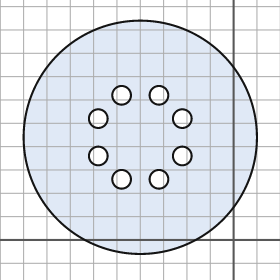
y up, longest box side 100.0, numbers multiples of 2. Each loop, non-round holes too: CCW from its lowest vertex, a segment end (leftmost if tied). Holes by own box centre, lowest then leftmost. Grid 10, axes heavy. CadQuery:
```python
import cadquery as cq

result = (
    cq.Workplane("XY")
    .moveTo(-40.0, 44.0)
    .circle(50.0)
    .moveTo(-48.0, 26.0)
    .circle(4.0)
    .moveTo(-32.0, 26.0)
    .circle(4.0)
    .moveTo(-58.0, 36.0)
    .circle(4.0)
    .moveTo(-22.0, 36.0)
    .circle(4.0)
    .moveTo(-58.0, 52.0)
    .circle(4.0)
    .moveTo(-22.0, 52.0)
    .circle(4.0)
    .moveTo(-48.0, 62.0)
    .circle(4.0)
    .moveTo(-32.0, 62.0)
    .circle(4.0)
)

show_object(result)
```